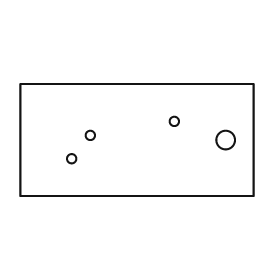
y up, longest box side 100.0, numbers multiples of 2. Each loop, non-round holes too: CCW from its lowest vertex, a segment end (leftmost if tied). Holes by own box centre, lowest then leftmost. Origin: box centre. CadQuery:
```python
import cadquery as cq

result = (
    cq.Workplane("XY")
    .moveTo(-50.0, -24.0)
    .lineTo(50.0, -24.0)
    .lineTo(50.0, 24.0)
    .lineTo(-50.0, 24.0)
    .close()
    .moveTo(-28.0, -8.0)
    .circle(2.0)
    .moveTo(38.0, 0.0)
    .circle(4.0)
    .moveTo(-20.0, 2.0)
    .circle(2.0)
    .moveTo(16.0, 8.0)
    .circle(2.0)
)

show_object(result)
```